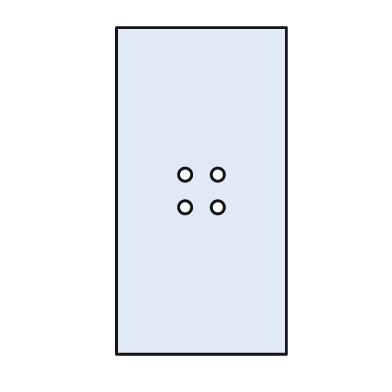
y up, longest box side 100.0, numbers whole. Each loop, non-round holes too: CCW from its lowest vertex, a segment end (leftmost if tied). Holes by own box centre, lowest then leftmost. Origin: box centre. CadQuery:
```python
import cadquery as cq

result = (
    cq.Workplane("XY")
    .moveTo(-26.0, -50.0)
    .lineTo(26.0, -50.0)
    .lineTo(26.0, 50.0)
    .lineTo(-26.0, 50.0)
    .close()
    .moveTo(-5.0, -5.0)
    .circle(2.0)
    .moveTo(5.0, -5.0)
    .circle(2.0)
    .moveTo(-5.0, 5.0)
    .circle(2.0)
    .moveTo(5.0, 5.0)
    .circle(2.0)
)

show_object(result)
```